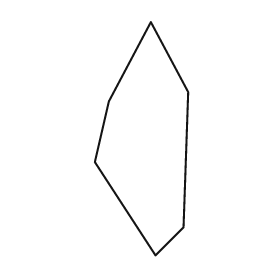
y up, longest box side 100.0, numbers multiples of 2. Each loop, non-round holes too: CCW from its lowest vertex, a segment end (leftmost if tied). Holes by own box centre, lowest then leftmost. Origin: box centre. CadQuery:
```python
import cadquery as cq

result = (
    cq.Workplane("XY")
    .moveTo(6.0, -50.0)
    .lineTo(18.0, -38.0)
    .lineTo(20.0, 20.0)
    .lineTo(4.0, 50.0)
    .lineTo(-14.0, 16.0)
    .lineTo(-20.0, -10.0)
    .close()
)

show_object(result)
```